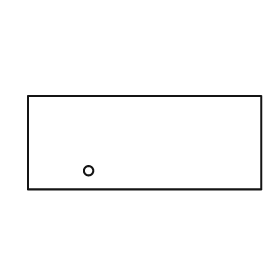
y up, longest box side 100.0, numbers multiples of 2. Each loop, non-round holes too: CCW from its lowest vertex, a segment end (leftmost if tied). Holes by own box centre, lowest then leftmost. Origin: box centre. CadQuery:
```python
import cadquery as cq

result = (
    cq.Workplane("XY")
    .moveTo(-50.0, -20.0)
    .lineTo(50.0, -20.0)
    .lineTo(50.0, 20.0)
    .lineTo(-50.0, 20.0)
    .close()
    .moveTo(-24.0, -12.0)
    .circle(2.0)
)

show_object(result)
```